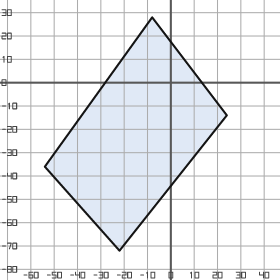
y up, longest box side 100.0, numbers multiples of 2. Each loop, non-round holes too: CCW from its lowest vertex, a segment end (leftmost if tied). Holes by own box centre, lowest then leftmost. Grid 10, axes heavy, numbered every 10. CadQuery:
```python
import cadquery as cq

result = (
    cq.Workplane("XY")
    .moveTo(-22.0, -72.0)
    .lineTo(24.0, -14.0)
    .lineTo(-8.0, 28.0)
    .lineTo(-54.0, -36.0)
    .close()
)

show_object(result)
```